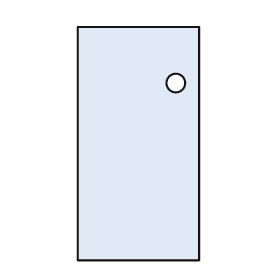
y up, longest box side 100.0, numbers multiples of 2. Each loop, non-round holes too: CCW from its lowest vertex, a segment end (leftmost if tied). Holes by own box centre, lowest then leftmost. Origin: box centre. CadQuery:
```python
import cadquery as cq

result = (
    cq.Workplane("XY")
    .moveTo(-26.0, -50.0)
    .lineTo(26.0, -50.0)
    .lineTo(26.0, 50.0)
    .lineTo(-26.0, 50.0)
    .close()
    .moveTo(16.0, 26.0)
    .circle(4.0)
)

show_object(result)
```